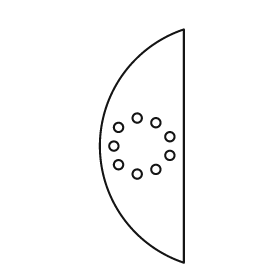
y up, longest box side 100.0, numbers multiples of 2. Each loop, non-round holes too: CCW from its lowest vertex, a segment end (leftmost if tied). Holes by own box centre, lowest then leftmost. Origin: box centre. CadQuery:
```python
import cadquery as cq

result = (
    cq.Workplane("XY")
    .moveTo(18.0, -50.0)
    .lineTo(18.0, 50.0)
    .threePointArc((-18.0, 0.0), (18.0, -50.0))
    .close()
    .moveTo(-2.0, -12.0)
    .circle(2.0)
    .moveTo(6.0, -10.0)
    .circle(2.0)
    .moveTo(-10.0, -8.0)
    .circle(2.0)
    .moveTo(12.0, -4.0)
    .circle(2.0)
    .moveTo(-12.0, 0.0)
    .circle(2.0)
    .moveTo(12.0, 4.0)
    .circle(2.0)
    .moveTo(-10.0, 8.0)
    .circle(2.0)
    .moveTo(6.0, 10.0)
    .circle(2.0)
    .moveTo(-2.0, 12.0)
    .circle(2.0)
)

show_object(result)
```